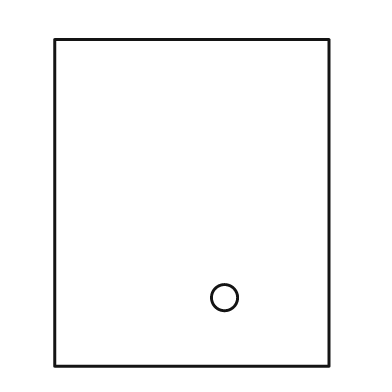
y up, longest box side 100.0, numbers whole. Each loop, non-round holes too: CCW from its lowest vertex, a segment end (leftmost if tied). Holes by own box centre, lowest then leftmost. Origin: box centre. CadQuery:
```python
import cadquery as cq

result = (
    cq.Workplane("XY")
    .moveTo(-42.0, -50.0)
    .lineTo(42.0, -50.0)
    .lineTo(42.0, 50.0)
    .lineTo(-42.0, 50.0)
    .close()
    .moveTo(10.0, -29.0)
    .circle(4.0)
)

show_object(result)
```